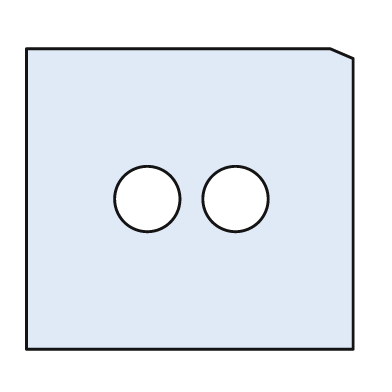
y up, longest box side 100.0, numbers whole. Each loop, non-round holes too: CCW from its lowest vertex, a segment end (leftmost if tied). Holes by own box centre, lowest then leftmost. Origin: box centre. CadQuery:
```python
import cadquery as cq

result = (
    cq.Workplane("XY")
    .moveTo(-50.0, -46.0)
    .lineTo(50.0, -46.0)
    .lineTo(50.0, 43.0)
    .lineTo(43.0, 46.0)
    .lineTo(-50.0, 46.0)
    .close()
    .moveTo(-13.0, 0.0)
    .circle(10.0)
    .moveTo(14.0, 0.0)
    .circle(10.0)
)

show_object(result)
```